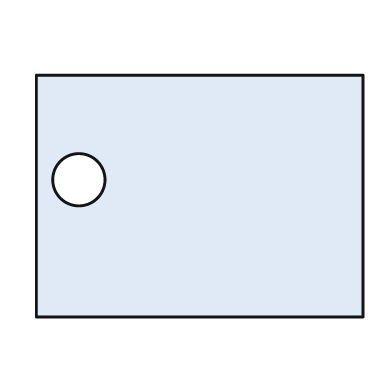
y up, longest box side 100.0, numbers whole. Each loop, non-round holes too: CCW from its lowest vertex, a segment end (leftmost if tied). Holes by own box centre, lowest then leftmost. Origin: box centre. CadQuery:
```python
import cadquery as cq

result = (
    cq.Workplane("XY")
    .moveTo(-50.0, -37.0)
    .lineTo(50.0, -37.0)
    .lineTo(50.0, 37.0)
    .lineTo(-50.0, 37.0)
    .close()
    .moveTo(-37.0, 5.0)
    .circle(8.0)
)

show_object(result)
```